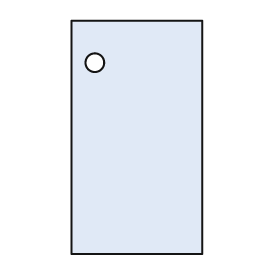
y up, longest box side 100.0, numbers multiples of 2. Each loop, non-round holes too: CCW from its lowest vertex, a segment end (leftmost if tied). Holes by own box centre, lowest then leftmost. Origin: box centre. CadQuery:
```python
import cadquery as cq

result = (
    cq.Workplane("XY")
    .moveTo(-28.0, -50.0)
    .lineTo(28.0, -50.0)
    .lineTo(28.0, 50.0)
    .lineTo(-28.0, 50.0)
    .close()
    .moveTo(-18.0, 32.0)
    .circle(4.0)
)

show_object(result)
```